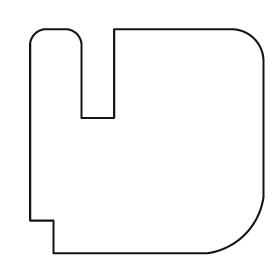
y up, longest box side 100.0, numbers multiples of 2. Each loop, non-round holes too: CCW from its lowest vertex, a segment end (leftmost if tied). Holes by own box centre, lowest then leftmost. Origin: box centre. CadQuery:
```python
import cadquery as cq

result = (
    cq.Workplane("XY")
    .moveTo(-40.0, -48.0)
    .lineTo(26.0, -48.0)
    .threePointArc((42.0, -40.0), (50.0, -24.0))
    .lineTo(50.0, 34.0)
    .threePointArc((46.0, 44.0), (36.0, 48.0))
    .lineTo(-14.0, 48.0)
    .lineTo(-14.0, 10.0)
    .lineTo(-28.0, 10.0)
    .lineTo(-28.0, 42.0)
    .threePointArc((-30.0, 46.0), (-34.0, 48.0))
    .lineTo(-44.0, 48.0)
    .threePointArc((-48.0, 46.0), (-50.0, 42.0))
    .lineTo(-50.0, -34.0)
    .lineTo(-40.0, -34.0)
    .close()
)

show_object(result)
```